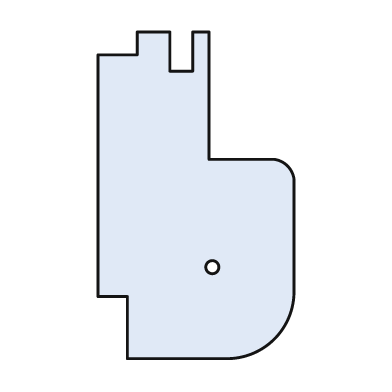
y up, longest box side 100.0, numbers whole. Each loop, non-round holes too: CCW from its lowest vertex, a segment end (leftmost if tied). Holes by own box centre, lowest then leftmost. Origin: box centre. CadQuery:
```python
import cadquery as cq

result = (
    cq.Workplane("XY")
    .moveTo(-21.0, -50.0)
    .lineTo(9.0, -50.0)
    .threePointArc((24.0, -44.0), (30.0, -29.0))
    .lineTo(30.0, 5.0)
    .threePointArc((28.0, 9.0), (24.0, 11.0))
    .lineTo(4.0, 11.0)
    .lineTo(4.0, 50.0)
    .lineTo(-1.0, 50.0)
    .lineTo(-1.0, 38.0)
    .lineTo(-8.0, 38.0)
    .lineTo(-8.0, 50.0)
    .lineTo(-18.0, 50.0)
    .lineTo(-18.0, 43.0)
    .lineTo(-30.0, 43.0)
    .lineTo(-30.0, -31.0)
    .lineTo(-21.0, -31.0)
    .close()
    .moveTo(5.0, -22.0)
    .circle(2.0)
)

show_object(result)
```